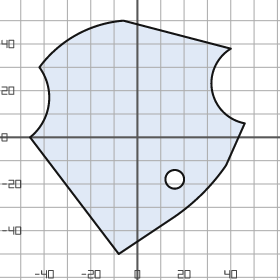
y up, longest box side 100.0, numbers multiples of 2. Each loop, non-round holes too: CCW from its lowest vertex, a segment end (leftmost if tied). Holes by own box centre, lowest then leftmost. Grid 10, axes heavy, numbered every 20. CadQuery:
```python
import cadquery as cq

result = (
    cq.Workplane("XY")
    .moveTo(-8.0, -50.0)
    .lineTo(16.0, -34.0)
    .threePointArc((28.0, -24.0), (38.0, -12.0))
    .lineTo(46.0, 6.0)
    .threePointArc((32.0, 20.0), (40.0, 38.0))
    .lineTo(-6.0, 50.0)
    .threePointArc((-26.0, 44.0), (-42.0, 30.0))
    .threePointArc((-38.0, 14.0), (-46.0, 0.0))
    .close()
    .moveTo(16.0, -18.0)
    .circle(4.0)
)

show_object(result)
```